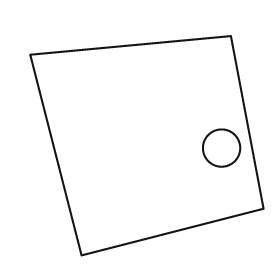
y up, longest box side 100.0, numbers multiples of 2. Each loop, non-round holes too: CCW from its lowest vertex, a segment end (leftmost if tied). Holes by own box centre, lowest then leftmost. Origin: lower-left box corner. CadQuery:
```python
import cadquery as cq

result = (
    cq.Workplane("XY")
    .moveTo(22.0, 0.0)
    .lineTo(100.0, 20.0)
    .lineTo(86.0, 94.0)
    .lineTo(0.0, 86.0)
    .close()
    .moveTo(82.0, 46.0)
    .circle(8.0)
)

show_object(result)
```